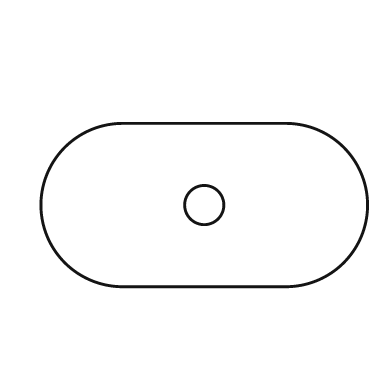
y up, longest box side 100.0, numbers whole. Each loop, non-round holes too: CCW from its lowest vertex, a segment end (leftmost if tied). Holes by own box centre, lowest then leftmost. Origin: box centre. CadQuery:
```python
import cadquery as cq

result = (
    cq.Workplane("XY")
    .moveTo(-25.0, -25.0)
    .lineTo(25.0, -25.0)
    .threePointArc((50.0, 0.0), (25.0, 25.0))
    .lineTo(-25.0, 25.0)
    .threePointArc((-50.0, 0.0), (-25.0, -25.0))
    .close()
    .moveTo(0.0, 0.0)
    .circle(6.0)
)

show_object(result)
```